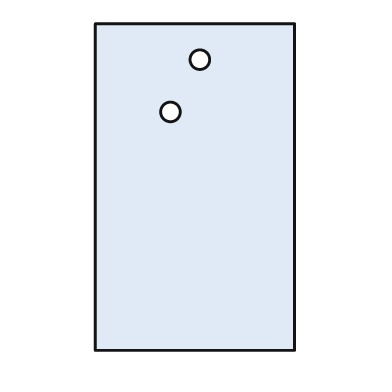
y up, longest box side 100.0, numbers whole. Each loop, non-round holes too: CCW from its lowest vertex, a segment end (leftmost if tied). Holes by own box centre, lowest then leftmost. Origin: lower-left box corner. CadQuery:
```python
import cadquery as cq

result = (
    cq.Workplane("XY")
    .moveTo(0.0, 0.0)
    .lineTo(61.0, 0.0)
    .lineTo(61.0, 100.0)
    .lineTo(0.0, 100.0)
    .close()
    .moveTo(23.0, 73.0)
    .circle(3.0)
    .moveTo(32.0, 89.0)
    .circle(3.0)
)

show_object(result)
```